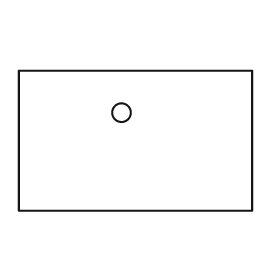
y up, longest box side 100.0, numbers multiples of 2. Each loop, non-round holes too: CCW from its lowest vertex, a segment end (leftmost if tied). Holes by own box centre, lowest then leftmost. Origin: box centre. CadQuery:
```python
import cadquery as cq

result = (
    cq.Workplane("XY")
    .moveTo(-50.0, -30.0)
    .lineTo(50.0, -30.0)
    .lineTo(50.0, 30.0)
    .lineTo(-50.0, 30.0)
    .close()
    .moveTo(-6.0, 12.0)
    .circle(4.0)
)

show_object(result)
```